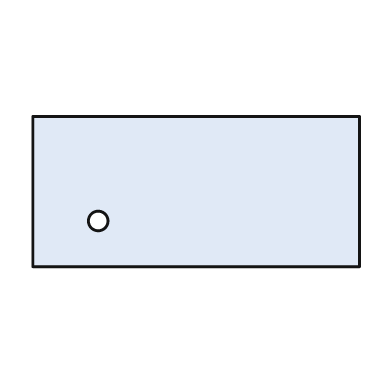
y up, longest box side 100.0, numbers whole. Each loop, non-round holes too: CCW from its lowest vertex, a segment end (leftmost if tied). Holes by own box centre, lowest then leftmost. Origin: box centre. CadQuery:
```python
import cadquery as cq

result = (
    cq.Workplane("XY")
    .moveTo(-50.0, -23.0)
    .lineTo(50.0, -23.0)
    .lineTo(50.0, 23.0)
    .lineTo(-50.0, 23.0)
    .close()
    .moveTo(-30.0, -9.0)
    .circle(3.0)
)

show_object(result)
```